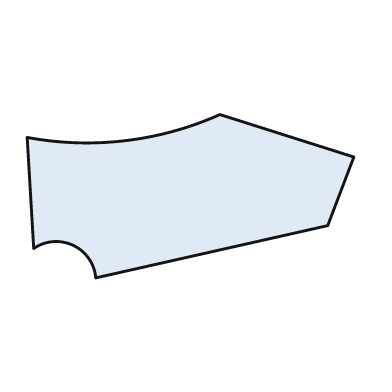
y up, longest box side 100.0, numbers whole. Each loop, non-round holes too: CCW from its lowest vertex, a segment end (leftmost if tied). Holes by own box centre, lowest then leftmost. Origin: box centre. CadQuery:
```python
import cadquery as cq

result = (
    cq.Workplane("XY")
    .moveTo(-29.0, -25.0)
    .lineTo(42.0, -9.0)
    .lineTo(50.0, 12.0)
    .lineTo(9.0, 25.0)
    .threePointArc((-20.0, 17.0), (-50.0, 18.0))
    .lineTo(-48.0, -16.0)
    .threePointArc((-36.0, -15.0), (-29.0, -25.0))
    .close()
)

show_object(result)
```